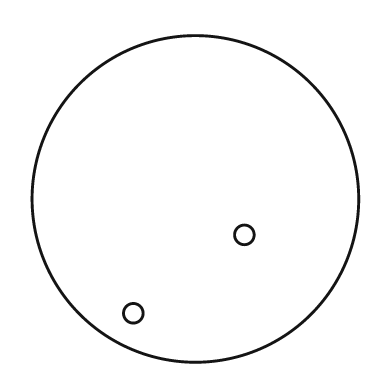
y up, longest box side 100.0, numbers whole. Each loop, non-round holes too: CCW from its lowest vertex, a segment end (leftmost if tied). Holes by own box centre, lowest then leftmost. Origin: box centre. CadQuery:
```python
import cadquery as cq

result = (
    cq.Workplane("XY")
    .moveTo(0.0, 0.0)
    .circle(50.0)
    .moveTo(-19.0, -35.0)
    .circle(3.0)
    .moveTo(15.0, -11.0)
    .circle(3.0)
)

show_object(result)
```